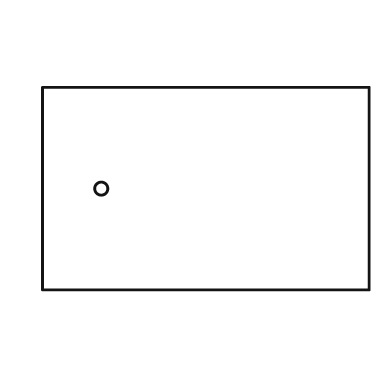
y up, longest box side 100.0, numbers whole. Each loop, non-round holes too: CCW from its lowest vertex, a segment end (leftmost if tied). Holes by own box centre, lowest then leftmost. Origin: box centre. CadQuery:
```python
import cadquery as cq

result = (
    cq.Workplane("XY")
    .moveTo(-50.0, -31.0)
    .lineTo(50.0, -31.0)
    .lineTo(50.0, 31.0)
    .lineTo(-50.0, 31.0)
    .close()
    .moveTo(-32.0, 0.0)
    .circle(2.0)
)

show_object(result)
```